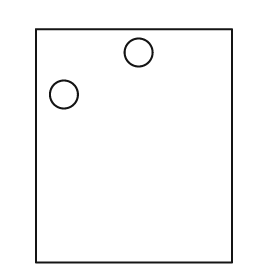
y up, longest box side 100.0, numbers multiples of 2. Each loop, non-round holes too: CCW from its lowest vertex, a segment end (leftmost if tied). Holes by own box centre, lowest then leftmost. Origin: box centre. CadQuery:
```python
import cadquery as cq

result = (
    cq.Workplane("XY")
    .moveTo(-42.0, -50.0)
    .lineTo(42.0, -50.0)
    .lineTo(42.0, 50.0)
    .lineTo(-42.0, 50.0)
    .close()
    .moveTo(-30.0, 22.0)
    .circle(6.0)
    .moveTo(2.0, 40.0)
    .circle(6.0)
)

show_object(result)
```